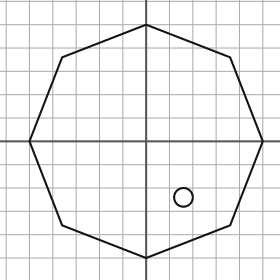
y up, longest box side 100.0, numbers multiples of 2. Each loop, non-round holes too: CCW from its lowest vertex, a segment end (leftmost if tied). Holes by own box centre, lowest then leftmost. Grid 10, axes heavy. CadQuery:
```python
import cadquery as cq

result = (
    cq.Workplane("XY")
    .moveTo(0.0, -50.0)
    .lineTo(36.0, -36.0)
    .lineTo(50.0, 0.0)
    .lineTo(36.0, 36.0)
    .lineTo(0.0, 50.0)
    .lineTo(-36.0, 36.0)
    .lineTo(-50.0, 0.0)
    .lineTo(-36.0, -36.0)
    .close()
    .moveTo(16.0, -24.0)
    .circle(4.0)
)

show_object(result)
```